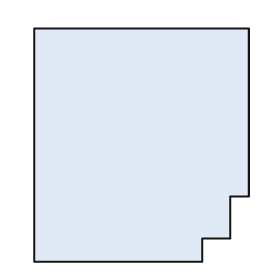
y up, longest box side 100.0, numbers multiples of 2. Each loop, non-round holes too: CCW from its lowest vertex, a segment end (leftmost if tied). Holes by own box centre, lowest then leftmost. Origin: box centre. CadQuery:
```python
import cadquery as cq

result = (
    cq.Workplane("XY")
    .moveTo(-46.0, -50.0)
    .lineTo(26.0, -50.0)
    .lineTo(26.0, -40.0)
    .lineTo(38.0, -40.0)
    .lineTo(38.0, -22.0)
    .lineTo(46.0, -22.0)
    .lineTo(46.0, 50.0)
    .lineTo(-46.0, 50.0)
    .close()
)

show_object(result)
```